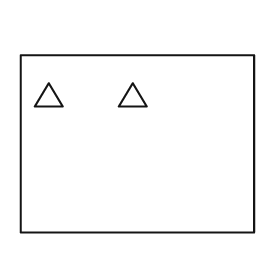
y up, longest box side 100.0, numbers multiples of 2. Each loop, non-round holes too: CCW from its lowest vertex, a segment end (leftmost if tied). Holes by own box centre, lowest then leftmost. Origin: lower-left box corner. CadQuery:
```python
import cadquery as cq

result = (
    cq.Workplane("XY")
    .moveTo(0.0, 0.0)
    .lineTo(100.0, 0.0)
    .lineTo(100.0, 76.0)
    .lineTo(0.0, 76.0)
    .close()
    .moveTo(6.0, 54.0)
    .lineTo(18.0, 54.0)
    .lineTo(12.0, 64.0)
    .close()
    .moveTo(42.0, 54.0)
    .lineTo(54.0, 54.0)
    .lineTo(48.0, 64.0)
    .close()
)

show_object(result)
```